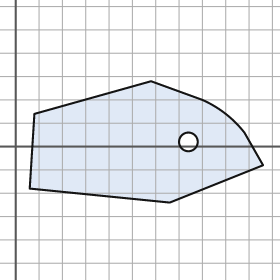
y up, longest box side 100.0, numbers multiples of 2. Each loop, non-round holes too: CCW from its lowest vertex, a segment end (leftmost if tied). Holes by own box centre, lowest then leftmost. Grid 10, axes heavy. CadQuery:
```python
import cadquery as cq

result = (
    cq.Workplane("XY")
    .moveTo(66.0, -24.0)
    .lineTo(106.0, -8.0)
    .lineTo(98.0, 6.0)
    .threePointArc((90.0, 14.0), (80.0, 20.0))
    .lineTo(58.0, 28.0)
    .lineTo(8.0, 14.0)
    .lineTo(6.0, -18.0)
    .close()
    .moveTo(74.0, 2.0)
    .circle(4.0)
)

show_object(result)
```